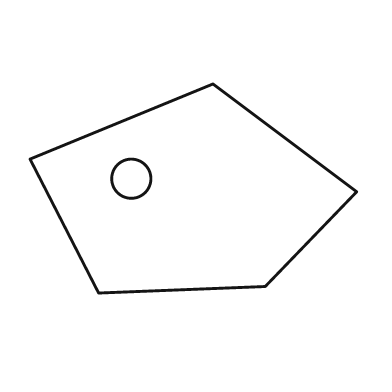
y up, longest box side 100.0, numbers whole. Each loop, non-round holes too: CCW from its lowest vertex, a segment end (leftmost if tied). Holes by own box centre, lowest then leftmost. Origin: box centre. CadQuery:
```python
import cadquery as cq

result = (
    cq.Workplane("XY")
    .moveTo(-29.0, -32.0)
    .lineTo(22.0, -30.0)
    .lineTo(50.0, -1.0)
    .lineTo(6.0, 32.0)
    .lineTo(-50.0, 9.0)
    .close()
    .moveTo(-19.0, 3.0)
    .circle(6.0)
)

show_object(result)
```